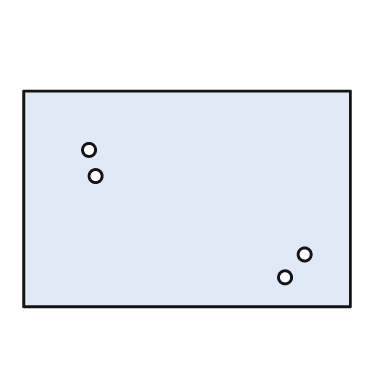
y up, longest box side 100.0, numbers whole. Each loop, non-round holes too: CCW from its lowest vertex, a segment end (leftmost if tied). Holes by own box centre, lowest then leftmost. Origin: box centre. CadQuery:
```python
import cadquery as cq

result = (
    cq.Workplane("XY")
    .moveTo(-50.0, -33.0)
    .lineTo(50.0, -33.0)
    .lineTo(50.0, 33.0)
    .lineTo(-50.0, 33.0)
    .close()
    .moveTo(30.0, -24.0)
    .circle(2.0)
    .moveTo(36.0, -17.0)
    .circle(2.0)
    .moveTo(-28.0, 7.0)
    .circle(2.0)
    .moveTo(-30.0, 15.0)
    .circle(2.0)
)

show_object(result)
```